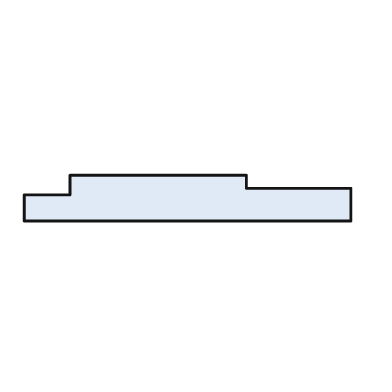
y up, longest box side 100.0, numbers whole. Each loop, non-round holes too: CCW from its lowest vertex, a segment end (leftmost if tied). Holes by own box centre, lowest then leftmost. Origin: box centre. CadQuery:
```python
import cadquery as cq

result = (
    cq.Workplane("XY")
    .moveTo(-50.0, -7.0)
    .lineTo(50.0, -7.0)
    .lineTo(50.0, 3.0)
    .lineTo(18.0, 3.0)
    .lineTo(18.0, 7.0)
    .lineTo(-36.0, 7.0)
    .lineTo(-36.0, 1.0)
    .lineTo(-50.0, 1.0)
    .close()
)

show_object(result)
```